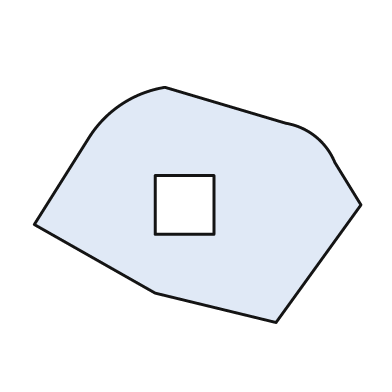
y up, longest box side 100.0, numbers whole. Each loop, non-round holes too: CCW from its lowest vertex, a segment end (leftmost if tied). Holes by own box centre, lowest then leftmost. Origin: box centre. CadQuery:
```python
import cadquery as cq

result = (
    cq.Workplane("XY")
    .moveTo(24.0, -36.0)
    .lineTo(50.0, 0.0)
    .lineTo(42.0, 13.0)
    .threePointArc((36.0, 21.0), (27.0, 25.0))
    .lineTo(-10.0, 36.0)
    .threePointArc((-23.0, 31.0), (-33.0, 21.0))
    .lineTo(-50.0, -6.0)
    .lineTo(-13.0, -27.0)
    .close()
    .moveTo(-13.0, -9.0)
    .lineTo(5.0, -9.0)
    .lineTo(5.0, 9.0)
    .lineTo(-13.0, 9.0)
    .close()
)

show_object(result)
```